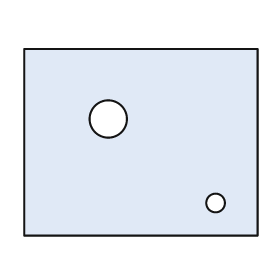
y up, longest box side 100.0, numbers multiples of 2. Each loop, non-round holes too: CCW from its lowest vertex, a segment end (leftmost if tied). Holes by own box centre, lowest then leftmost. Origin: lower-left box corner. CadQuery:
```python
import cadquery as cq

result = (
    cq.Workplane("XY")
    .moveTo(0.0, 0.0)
    .lineTo(100.0, 0.0)
    .lineTo(100.0, 80.0)
    .lineTo(0.0, 80.0)
    .close()
    .moveTo(82.0, 14.0)
    .circle(4.0)
    .moveTo(36.0, 50.0)
    .circle(8.0)
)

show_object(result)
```